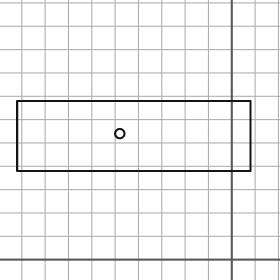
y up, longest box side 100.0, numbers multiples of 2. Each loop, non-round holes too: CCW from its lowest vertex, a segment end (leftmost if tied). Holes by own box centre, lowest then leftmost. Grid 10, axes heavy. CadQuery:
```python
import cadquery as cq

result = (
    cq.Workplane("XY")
    .moveTo(-92.0, 38.0)
    .lineTo(8.0, 38.0)
    .lineTo(8.0, 68.0)
    .lineTo(-92.0, 68.0)
    .close()
    .moveTo(-48.0, 54.0)
    .circle(2.0)
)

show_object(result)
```